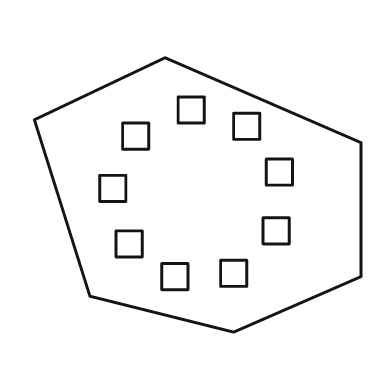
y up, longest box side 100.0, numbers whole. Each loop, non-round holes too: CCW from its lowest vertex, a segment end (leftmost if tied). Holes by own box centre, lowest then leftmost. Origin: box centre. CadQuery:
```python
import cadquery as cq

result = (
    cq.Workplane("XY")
    .moveTo(11.0, -42.0)
    .lineTo(50.0, -25.0)
    .lineTo(50.0, 16.0)
    .lineTo(-10.0, 42.0)
    .lineTo(-50.0, 23.0)
    .lineTo(-33.0, -31.0)
    .close()
    .moveTo(-11.0, -29.0)
    .lineTo(-3.0, -29.0)
    .lineTo(-3.0, -21.0)
    .lineTo(-11.0, -21.0)
    .close()
    .moveTo(7.0, -28.0)
    .lineTo(15.0, -28.0)
    .lineTo(15.0, -20.0)
    .lineTo(7.0, -20.0)
    .close()
    .moveTo(-25.0, -19.0)
    .lineTo(-17.0, -19.0)
    .lineTo(-17.0, -11.0)
    .lineTo(-25.0, -11.0)
    .close()
    .moveTo(20.0, -15.0)
    .lineTo(28.0, -15.0)
    .lineTo(28.0, -7.0)
    .lineTo(20.0, -7.0)
    .close()
    .moveTo(-30.0, -2.0)
    .lineTo(-22.0, -2.0)
    .lineTo(-22.0, 6.0)
    .lineTo(-30.0, 6.0)
    .close()
    .moveTo(21.0, 3.0)
    .lineTo(29.0, 3.0)
    .lineTo(29.0, 11.0)
    .lineTo(21.0, 11.0)
    .close()
    .moveTo(-23.0, 14.0)
    .lineTo(-15.0, 14.0)
    .lineTo(-15.0, 22.0)
    .lineTo(-23.0, 22.0)
    .close()
    .moveTo(11.0, 17.0)
    .lineTo(19.0, 17.0)
    .lineTo(19.0, 25.0)
    .lineTo(11.0, 25.0)
    .close()
    .moveTo(-6.0, 22.0)
    .lineTo(2.0, 22.0)
    .lineTo(2.0, 30.0)
    .lineTo(-6.0, 30.0)
    .close()
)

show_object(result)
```